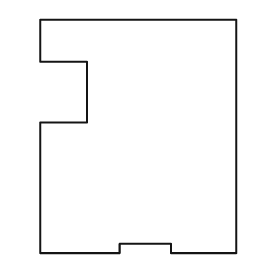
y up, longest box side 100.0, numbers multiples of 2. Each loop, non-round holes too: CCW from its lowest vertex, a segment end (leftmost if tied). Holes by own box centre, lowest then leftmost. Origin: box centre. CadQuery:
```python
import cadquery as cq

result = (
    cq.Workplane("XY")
    .moveTo(-42.0, -50.0)
    .lineTo(-8.0, -50.0)
    .lineTo(-8.0, -46.0)
    .lineTo(14.0, -46.0)
    .lineTo(14.0, -50.0)
    .lineTo(42.0, -50.0)
    .lineTo(42.0, 50.0)
    .lineTo(-42.0, 50.0)
    .lineTo(-42.0, 32.0)
    .lineTo(-22.0, 32.0)
    .lineTo(-22.0, 6.0)
    .lineTo(-42.0, 6.0)
    .close()
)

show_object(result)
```